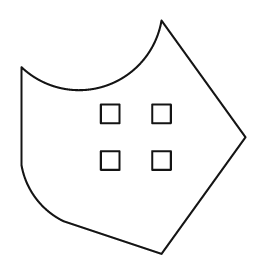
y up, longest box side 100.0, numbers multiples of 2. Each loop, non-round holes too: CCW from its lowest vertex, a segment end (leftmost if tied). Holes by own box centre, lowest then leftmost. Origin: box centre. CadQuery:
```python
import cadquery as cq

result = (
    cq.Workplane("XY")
    .moveTo(12.0, -50.0)
    .lineTo(48.0, 0.0)
    .lineTo(12.0, 50.0)
    .threePointArc((-12.0, 22.0), (-48.0, 30.0))
    .lineTo(-48.0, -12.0)
    .threePointArc((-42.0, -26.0), (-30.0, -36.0))
    .close()
    .moveTo(-14.0, -14.0)
    .lineTo(-6.0, -14.0)
    .lineTo(-6.0, -6.0)
    .lineTo(-14.0, -6.0)
    .close()
    .moveTo(8.0, -14.0)
    .lineTo(16.0, -14.0)
    .lineTo(16.0, -6.0)
    .lineTo(8.0, -6.0)
    .close()
    .moveTo(-14.0, 6.0)
    .lineTo(-6.0, 6.0)
    .lineTo(-6.0, 14.0)
    .lineTo(-14.0, 14.0)
    .close()
    .moveTo(8.0, 6.0)
    .lineTo(16.0, 6.0)
    .lineTo(16.0, 14.0)
    .lineTo(8.0, 14.0)
    .close()
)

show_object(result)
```